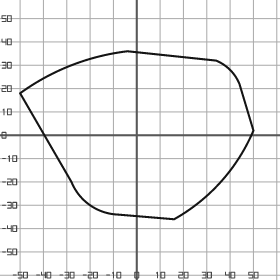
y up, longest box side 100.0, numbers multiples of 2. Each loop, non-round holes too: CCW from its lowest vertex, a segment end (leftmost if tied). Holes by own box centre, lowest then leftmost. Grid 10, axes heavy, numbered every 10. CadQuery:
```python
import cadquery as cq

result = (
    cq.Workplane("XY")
    .moveTo(16.0, -36.0)
    .threePointArc((36.0, -20.0), (50.0, 2.0))
    .lineTo(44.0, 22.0)
    .threePointArc((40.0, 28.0), (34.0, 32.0))
    .lineTo(-4.0, 36.0)
    .threePointArc((-28.0, 30.0), (-50.0, 18.0))
    .lineTo(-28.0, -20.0)
    .threePointArc((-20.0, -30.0), (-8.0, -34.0))
    .close()
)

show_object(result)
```